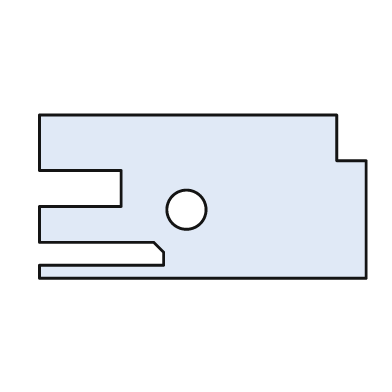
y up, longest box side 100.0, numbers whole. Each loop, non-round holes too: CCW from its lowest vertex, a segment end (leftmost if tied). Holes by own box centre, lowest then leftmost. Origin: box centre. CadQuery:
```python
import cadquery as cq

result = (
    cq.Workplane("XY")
    .moveTo(-50.0, -25.0)
    .lineTo(50.0, -25.0)
    .lineTo(50.0, 11.0)
    .lineTo(41.0, 11.0)
    .lineTo(41.0, 25.0)
    .lineTo(-50.0, 25.0)
    .lineTo(-50.0, 8.0)
    .lineTo(-25.0, 8.0)
    .lineTo(-25.0, -3.0)
    .lineTo(-50.0, -3.0)
    .lineTo(-50.0, -14.0)
    .lineTo(-15.0, -14.0)
    .lineTo(-12.0, -17.0)
    .lineTo(-12.0, -21.0)
    .lineTo(-50.0, -21.0)
    .close()
    .moveTo(-5.0, -4.0)
    .circle(6.0)
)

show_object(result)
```